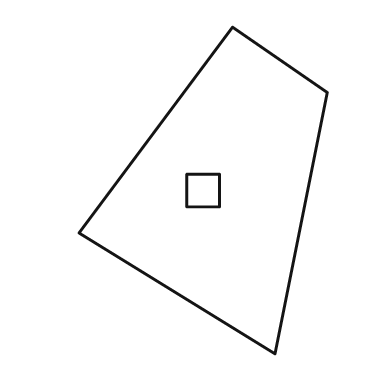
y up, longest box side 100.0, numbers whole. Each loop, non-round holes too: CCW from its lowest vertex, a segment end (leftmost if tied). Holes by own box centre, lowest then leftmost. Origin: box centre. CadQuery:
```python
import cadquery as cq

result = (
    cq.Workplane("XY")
    .moveTo(22.0, -50.0)
    .lineTo(38.0, 30.0)
    .lineTo(9.0, 50.0)
    .lineTo(-38.0, -13.0)
    .close()
    .moveTo(-5.0, -5.0)
    .lineTo(5.0, -5.0)
    .lineTo(5.0, 5.0)
    .lineTo(-5.0, 5.0)
    .close()
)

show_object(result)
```